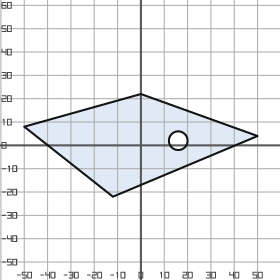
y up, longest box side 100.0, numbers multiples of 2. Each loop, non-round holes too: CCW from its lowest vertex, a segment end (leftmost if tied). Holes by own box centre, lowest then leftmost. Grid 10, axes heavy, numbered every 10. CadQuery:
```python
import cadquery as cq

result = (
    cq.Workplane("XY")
    .moveTo(-12.0, -22.0)
    .lineTo(50.0, 4.0)
    .lineTo(0.0, 22.0)
    .lineTo(-50.0, 8.0)
    .close()
    .moveTo(16.0, 2.0)
    .circle(4.0)
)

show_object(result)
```